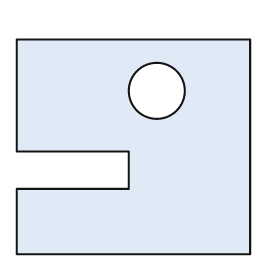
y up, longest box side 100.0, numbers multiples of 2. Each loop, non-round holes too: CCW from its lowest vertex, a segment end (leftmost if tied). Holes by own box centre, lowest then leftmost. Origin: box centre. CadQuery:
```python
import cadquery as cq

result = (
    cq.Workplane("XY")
    .moveTo(-50.0, -46.0)
    .lineTo(50.0, -46.0)
    .lineTo(50.0, 46.0)
    .lineTo(-50.0, 46.0)
    .lineTo(-50.0, -2.0)
    .lineTo(-2.0, -2.0)
    .lineTo(-2.0, -18.0)
    .lineTo(-50.0, -18.0)
    .close()
    .moveTo(10.0, 24.0)
    .circle(12.0)
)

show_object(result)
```